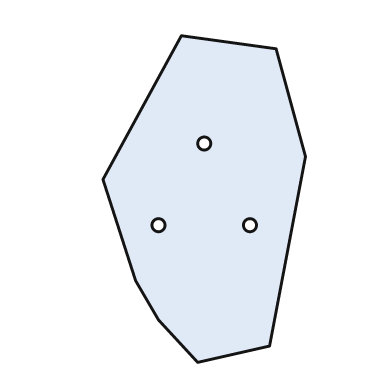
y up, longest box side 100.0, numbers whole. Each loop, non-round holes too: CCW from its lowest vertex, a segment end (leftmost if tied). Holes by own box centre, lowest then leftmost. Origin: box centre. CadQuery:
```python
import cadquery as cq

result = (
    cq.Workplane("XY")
    .moveTo(-2.0, -50.0)
    .lineTo(20.0, -45.0)
    .lineTo(31.0, 13.0)
    .lineTo(22.0, 46.0)
    .lineTo(-7.0, 50.0)
    .lineTo(-31.0, 6.0)
    .lineTo(-21.0, -25.0)
    .lineTo(-14.0, -37.0)
    .close()
    .moveTo(-14.0, -8.0)
    .circle(2.0)
    .moveTo(14.0, -8.0)
    .circle(2.0)
    .moveTo(0.0, 17.0)
    .circle(2.0)
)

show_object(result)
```